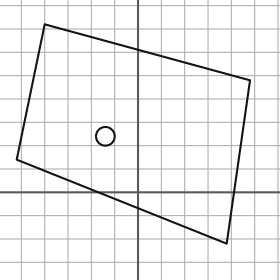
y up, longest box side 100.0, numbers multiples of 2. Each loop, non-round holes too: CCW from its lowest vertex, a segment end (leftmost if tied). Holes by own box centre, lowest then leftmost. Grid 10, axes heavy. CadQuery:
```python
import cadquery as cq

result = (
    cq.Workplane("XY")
    .moveTo(38.0, -22.0)
    .lineTo(48.0, 48.0)
    .lineTo(-40.0, 72.0)
    .lineTo(-52.0, 14.0)
    .close()
    .moveTo(-14.0, 24.0)
    .circle(4.0)
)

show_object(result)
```